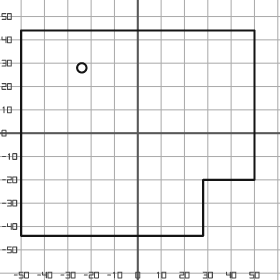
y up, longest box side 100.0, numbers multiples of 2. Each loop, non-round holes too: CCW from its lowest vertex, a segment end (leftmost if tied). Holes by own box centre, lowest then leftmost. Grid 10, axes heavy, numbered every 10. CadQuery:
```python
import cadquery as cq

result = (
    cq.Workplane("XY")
    .moveTo(-50.0, -44.0)
    .lineTo(28.0, -44.0)
    .lineTo(28.0, -20.0)
    .lineTo(50.0, -20.0)
    .lineTo(50.0, 44.0)
    .lineTo(-50.0, 44.0)
    .close()
    .moveTo(-24.0, 28.0)
    .circle(2.0)
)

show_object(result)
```